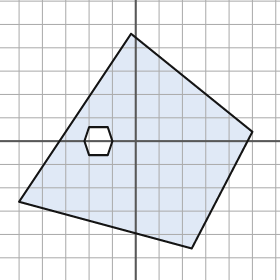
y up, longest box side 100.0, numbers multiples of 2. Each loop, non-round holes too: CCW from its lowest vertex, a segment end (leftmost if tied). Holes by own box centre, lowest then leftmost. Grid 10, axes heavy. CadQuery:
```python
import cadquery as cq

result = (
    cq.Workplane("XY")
    .moveTo(24.0, -46.0)
    .lineTo(50.0, 4.0)
    .lineTo(-2.0, 46.0)
    .lineTo(-50.0, -26.0)
    .close()
    .moveTo(-20.0, -6.0)
    .lineTo(-12.0, -6.0)
    .lineTo(-10.0, 0.0)
    .lineTo(-12.0, 6.0)
    .lineTo(-20.0, 6.0)
    .lineTo(-22.0, 0.0)
    .close()
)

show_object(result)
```